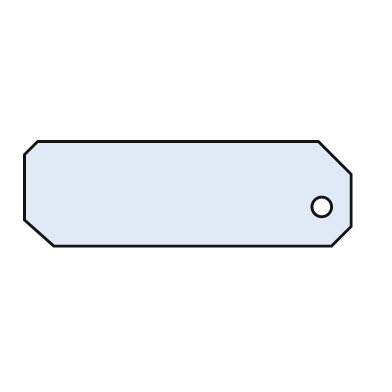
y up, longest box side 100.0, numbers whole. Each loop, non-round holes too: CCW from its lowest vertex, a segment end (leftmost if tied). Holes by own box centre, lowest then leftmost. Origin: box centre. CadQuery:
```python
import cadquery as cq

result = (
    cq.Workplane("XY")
    .moveTo(-41.0, -16.0)
    .lineTo(44.0, -16.0)
    .lineTo(50.0, -10.0)
    .lineTo(50.0, 6.0)
    .lineTo(40.0, 16.0)
    .lineTo(-46.0, 16.0)
    .lineTo(-50.0, 12.0)
    .lineTo(-50.0, -8.0)
    .close()
    .moveTo(41.0, -4.0)
    .circle(3.0)
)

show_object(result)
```